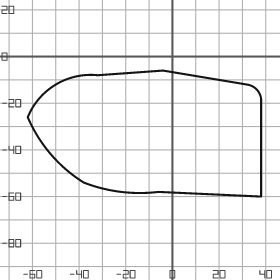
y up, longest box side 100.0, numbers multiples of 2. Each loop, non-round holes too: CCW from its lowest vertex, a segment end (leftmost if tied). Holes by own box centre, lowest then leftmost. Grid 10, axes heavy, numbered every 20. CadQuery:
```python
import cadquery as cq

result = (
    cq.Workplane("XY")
    .moveTo(38.0, -60.0)
    .lineTo(38.0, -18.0)
    .threePointArc((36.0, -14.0), (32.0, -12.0))
    .lineTo(-4.0, -6.0)
    .lineTo(-32.0, -8.0)
    .threePointArc((-50.0, -12.0), (-62.0, -26.0))
    .threePointArc((-52.0, -42.0), (-38.0, -54.0))
    .threePointArc((-22.0, -58.0), (-6.0, -58.0))
    .close()
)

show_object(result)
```